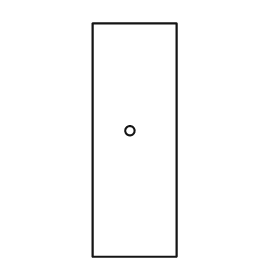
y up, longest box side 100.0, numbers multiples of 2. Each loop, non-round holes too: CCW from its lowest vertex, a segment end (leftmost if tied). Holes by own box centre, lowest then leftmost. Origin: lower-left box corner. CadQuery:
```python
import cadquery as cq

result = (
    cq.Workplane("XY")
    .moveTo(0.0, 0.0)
    .lineTo(36.0, 0.0)
    .lineTo(36.0, 100.0)
    .lineTo(0.0, 100.0)
    .close()
    .moveTo(16.0, 54.0)
    .circle(2.0)
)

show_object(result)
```